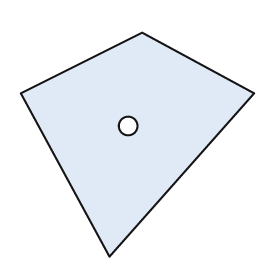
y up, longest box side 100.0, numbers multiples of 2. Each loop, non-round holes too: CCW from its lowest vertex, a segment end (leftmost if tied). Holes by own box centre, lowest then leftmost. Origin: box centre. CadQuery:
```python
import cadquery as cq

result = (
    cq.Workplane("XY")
    .moveTo(-12.0, -48.0)
    .lineTo(50.0, 22.0)
    .lineTo(2.0, 48.0)
    .lineTo(-50.0, 22.0)
    .close()
    .moveTo(-4.0, 8.0)
    .circle(4.0)
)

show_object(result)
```